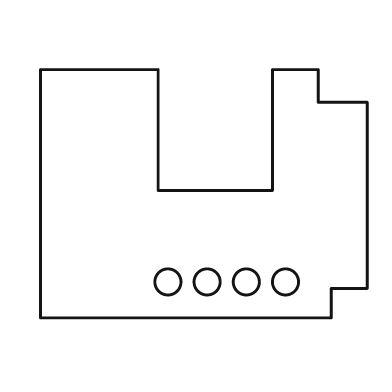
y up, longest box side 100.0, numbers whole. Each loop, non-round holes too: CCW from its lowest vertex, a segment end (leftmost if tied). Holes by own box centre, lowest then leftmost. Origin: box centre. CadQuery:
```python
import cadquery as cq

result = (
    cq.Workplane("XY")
    .moveTo(-50.0, -38.0)
    .lineTo(39.0, -38.0)
    .lineTo(39.0, -29.0)
    .lineTo(50.0, -29.0)
    .lineTo(50.0, 28.0)
    .lineTo(35.0, 28.0)
    .lineTo(35.0, 38.0)
    .lineTo(21.0, 38.0)
    .lineTo(21.0, 1.0)
    .lineTo(-14.0, 1.0)
    .lineTo(-14.0, 38.0)
    .lineTo(-50.0, 38.0)
    .close()
    .moveTo(-11.0, -27.0)
    .circle(4.0)
    .moveTo(1.0, -27.0)
    .circle(4.0)
    .moveTo(13.0, -27.0)
    .circle(4.0)
    .moveTo(25.0, -27.0)
    .circle(4.0)
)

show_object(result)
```